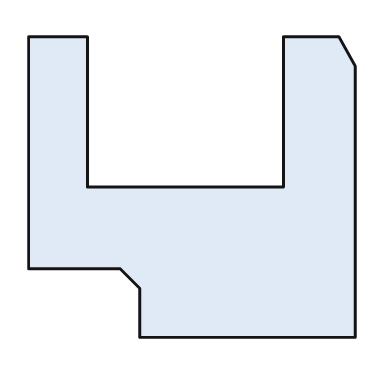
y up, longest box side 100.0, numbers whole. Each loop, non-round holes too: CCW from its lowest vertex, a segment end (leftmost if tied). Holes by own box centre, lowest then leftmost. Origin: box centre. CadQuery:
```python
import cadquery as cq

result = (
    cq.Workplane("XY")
    .moveTo(-16.0, -46.0)
    .lineTo(50.0, -46.0)
    .lineTo(50.0, 37.0)
    .lineTo(45.0, 46.0)
    .lineTo(28.0, 46.0)
    .lineTo(28.0, 0.0)
    .lineTo(-32.0, 0.0)
    .lineTo(-32.0, 46.0)
    .lineTo(-50.0, 46.0)
    .lineTo(-50.0, -25.0)
    .lineTo(-22.0, -25.0)
    .lineTo(-16.0, -31.0)
    .close()
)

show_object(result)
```